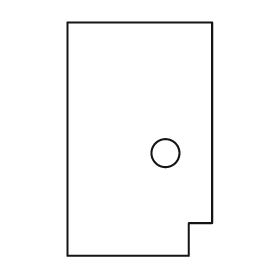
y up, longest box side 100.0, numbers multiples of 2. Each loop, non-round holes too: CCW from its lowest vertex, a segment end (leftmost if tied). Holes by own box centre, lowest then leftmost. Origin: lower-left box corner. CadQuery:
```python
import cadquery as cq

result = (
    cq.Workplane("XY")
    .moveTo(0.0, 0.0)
    .lineTo(52.0, 0.0)
    .lineTo(52.0, 14.0)
    .lineTo(62.0, 14.0)
    .lineTo(62.0, 100.0)
    .lineTo(0.0, 100.0)
    .close()
    .moveTo(42.0, 44.0)
    .circle(6.0)
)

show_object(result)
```